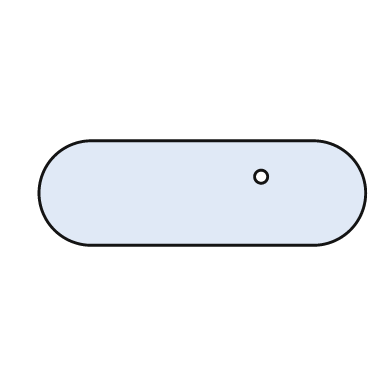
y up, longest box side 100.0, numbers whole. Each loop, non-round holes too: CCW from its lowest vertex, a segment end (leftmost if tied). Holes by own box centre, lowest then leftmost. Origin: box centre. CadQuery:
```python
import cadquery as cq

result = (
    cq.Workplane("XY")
    .moveTo(-34.0, -16.0)
    .lineTo(34.0, -16.0)
    .threePointArc((50.0, 0.0), (34.0, 16.0))
    .lineTo(-34.0, 16.0)
    .threePointArc((-50.0, 0.0), (-34.0, -16.0))
    .close()
    .moveTo(18.0, 5.0)
    .circle(2.0)
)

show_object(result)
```